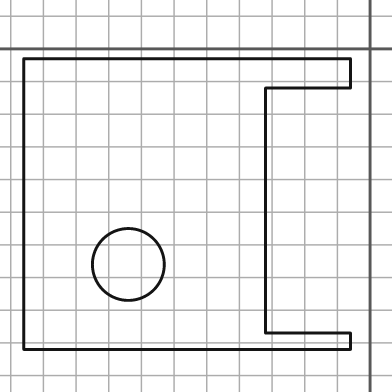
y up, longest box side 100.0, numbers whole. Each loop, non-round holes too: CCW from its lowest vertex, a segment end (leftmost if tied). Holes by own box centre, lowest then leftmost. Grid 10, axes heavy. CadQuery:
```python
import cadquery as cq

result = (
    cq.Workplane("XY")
    .moveTo(-106.0, -92.0)
    .lineTo(-6.0, -92.0)
    .lineTo(-6.0, -87.0)
    .lineTo(-32.0, -87.0)
    .lineTo(-32.0, -12.0)
    .lineTo(-6.0, -12.0)
    .lineTo(-6.0, -3.0)
    .lineTo(-106.0, -3.0)
    .close()
    .moveTo(-74.0, -66.0)
    .circle(11.0)
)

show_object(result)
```